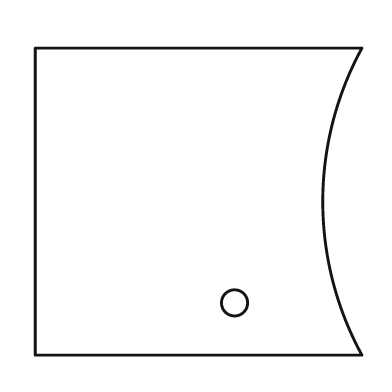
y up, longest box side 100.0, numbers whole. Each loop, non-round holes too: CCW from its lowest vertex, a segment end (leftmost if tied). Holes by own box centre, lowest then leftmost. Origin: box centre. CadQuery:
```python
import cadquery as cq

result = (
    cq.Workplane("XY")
    .moveTo(-50.0, -47.0)
    .lineTo(50.0, -47.0)
    .threePointArc((38.0, 0.0), (50.0, 47.0))
    .lineTo(-50.0, 47.0)
    .close()
    .moveTo(11.0, -31.0)
    .circle(4.0)
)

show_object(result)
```